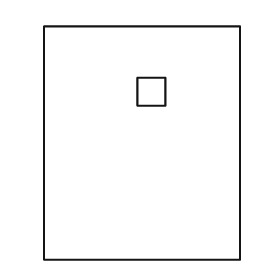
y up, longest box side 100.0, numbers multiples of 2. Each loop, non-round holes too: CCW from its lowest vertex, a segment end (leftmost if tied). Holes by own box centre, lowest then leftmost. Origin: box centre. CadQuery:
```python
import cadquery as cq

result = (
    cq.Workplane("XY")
    .moveTo(-42.0, -50.0)
    .lineTo(42.0, -50.0)
    .lineTo(42.0, 50.0)
    .lineTo(-42.0, 50.0)
    .close()
    .moveTo(-2.0, 16.0)
    .lineTo(10.0, 16.0)
    .lineTo(10.0, 28.0)
    .lineTo(-2.0, 28.0)
    .close()
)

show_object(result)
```